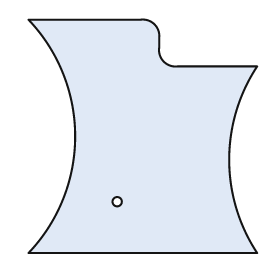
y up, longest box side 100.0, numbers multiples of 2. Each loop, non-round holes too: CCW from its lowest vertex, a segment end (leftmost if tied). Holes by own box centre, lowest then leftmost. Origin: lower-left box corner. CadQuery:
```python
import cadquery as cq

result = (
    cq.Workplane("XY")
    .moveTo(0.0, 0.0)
    .lineTo(98.0, 0.0)
    .threePointArc((86.0, 40.0), (98.0, 80.0))
    .lineTo(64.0, 80.0)
    .threePointArc((58.0, 82.0), (56.0, 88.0))
    .lineTo(56.0, 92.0)
    .threePointArc((54.0, 98.0), (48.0, 100.0))
    .lineTo(0.0, 100.0)
    .threePointArc((20.0, 50.0), (0.0, 0.0))
    .close()
    .moveTo(38.0, 22.0)
    .circle(2.0)
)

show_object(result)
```